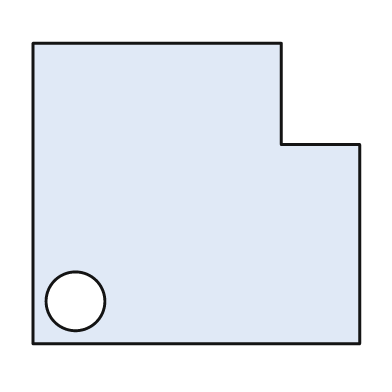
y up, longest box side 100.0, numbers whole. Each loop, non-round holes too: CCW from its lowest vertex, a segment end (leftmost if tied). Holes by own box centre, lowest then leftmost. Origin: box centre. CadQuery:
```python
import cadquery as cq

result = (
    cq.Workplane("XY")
    .moveTo(-50.0, -46.0)
    .lineTo(50.0, -46.0)
    .lineTo(50.0, 15.0)
    .lineTo(26.0, 15.0)
    .lineTo(26.0, 46.0)
    .lineTo(-50.0, 46.0)
    .close()
    .moveTo(-37.0, -33.0)
    .circle(9.0)
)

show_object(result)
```